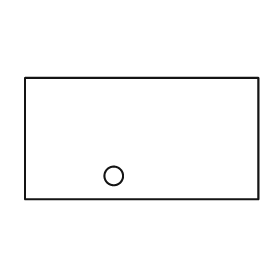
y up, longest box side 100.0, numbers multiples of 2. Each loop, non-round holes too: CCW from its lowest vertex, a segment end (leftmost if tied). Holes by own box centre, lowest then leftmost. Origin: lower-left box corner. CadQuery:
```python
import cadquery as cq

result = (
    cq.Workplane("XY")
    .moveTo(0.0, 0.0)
    .lineTo(100.0, 0.0)
    .lineTo(100.0, 52.0)
    .lineTo(0.0, 52.0)
    .close()
    .moveTo(38.0, 10.0)
    .circle(4.0)
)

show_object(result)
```